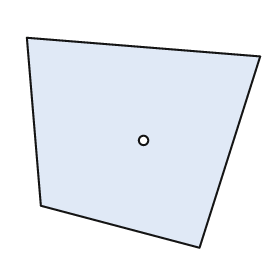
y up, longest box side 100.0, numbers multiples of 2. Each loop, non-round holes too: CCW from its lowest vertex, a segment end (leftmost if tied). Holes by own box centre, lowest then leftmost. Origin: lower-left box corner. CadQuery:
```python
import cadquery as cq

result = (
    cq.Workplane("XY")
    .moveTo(74.0, 0.0)
    .lineTo(100.0, 82.0)
    .lineTo(0.0, 90.0)
    .lineTo(6.0, 18.0)
    .close()
    .moveTo(50.0, 46.0)
    .circle(2.0)
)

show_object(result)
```